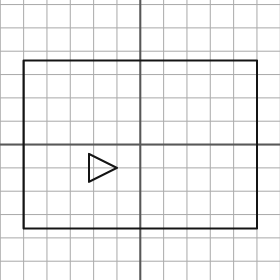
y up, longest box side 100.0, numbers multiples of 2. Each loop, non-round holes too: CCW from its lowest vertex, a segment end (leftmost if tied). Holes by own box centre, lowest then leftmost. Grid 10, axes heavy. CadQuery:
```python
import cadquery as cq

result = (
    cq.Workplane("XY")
    .moveTo(-50.0, -36.0)
    .lineTo(50.0, -36.0)
    .lineTo(50.0, 36.0)
    .lineTo(-50.0, 36.0)
    .close()
    .moveTo(-22.0, -16.0)
    .lineTo(-10.0, -10.0)
    .lineTo(-22.0, -4.0)
    .close()
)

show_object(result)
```